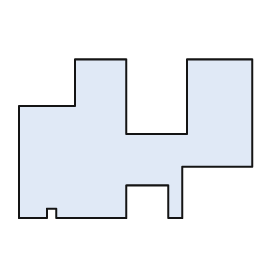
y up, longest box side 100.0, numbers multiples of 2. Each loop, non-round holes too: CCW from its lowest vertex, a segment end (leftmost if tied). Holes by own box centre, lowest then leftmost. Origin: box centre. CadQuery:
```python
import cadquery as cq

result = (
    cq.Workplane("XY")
    .moveTo(-50.0, -34.0)
    .lineTo(-38.0, -34.0)
    .lineTo(-38.0, -30.0)
    .lineTo(-34.0, -30.0)
    .lineTo(-34.0, -34.0)
    .lineTo(-4.0, -34.0)
    .lineTo(-4.0, -20.0)
    .lineTo(14.0, -20.0)
    .lineTo(14.0, -34.0)
    .lineTo(20.0, -34.0)
    .lineTo(20.0, -12.0)
    .lineTo(50.0, -12.0)
    .lineTo(50.0, 34.0)
    .lineTo(22.0, 34.0)
    .lineTo(22.0, 2.0)
    .lineTo(-4.0, 2.0)
    .lineTo(-4.0, 34.0)
    .lineTo(-26.0, 34.0)
    .lineTo(-26.0, 14.0)
    .lineTo(-50.0, 14.0)
    .close()
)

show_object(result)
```